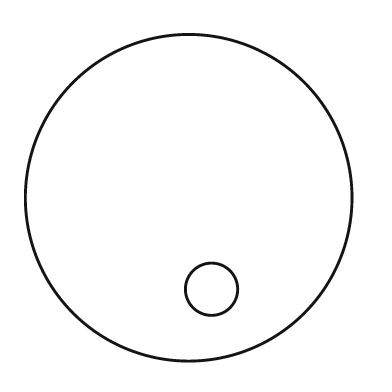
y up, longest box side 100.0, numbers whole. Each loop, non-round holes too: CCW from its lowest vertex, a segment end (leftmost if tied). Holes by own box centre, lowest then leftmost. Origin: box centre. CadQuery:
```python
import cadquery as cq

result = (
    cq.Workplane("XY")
    .moveTo(0.0, 0.0)
    .circle(50.0)
    .moveTo(7.0, -28.0)
    .circle(8.0)
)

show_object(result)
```